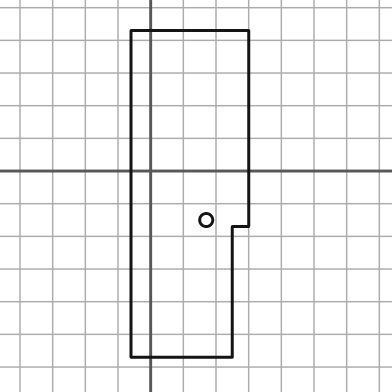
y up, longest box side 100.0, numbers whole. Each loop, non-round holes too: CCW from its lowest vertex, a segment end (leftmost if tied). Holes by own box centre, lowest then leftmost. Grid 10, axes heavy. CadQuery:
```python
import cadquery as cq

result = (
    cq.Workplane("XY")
    .moveTo(-6.0, -57.0)
    .lineTo(25.0, -57.0)
    .lineTo(25.0, -17.0)
    .lineTo(30.0, -17.0)
    .lineTo(30.0, 43.0)
    .lineTo(-6.0, 43.0)
    .close()
    .moveTo(17.0, -15.0)
    .circle(2.0)
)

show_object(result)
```